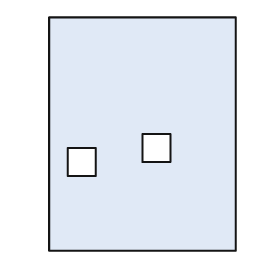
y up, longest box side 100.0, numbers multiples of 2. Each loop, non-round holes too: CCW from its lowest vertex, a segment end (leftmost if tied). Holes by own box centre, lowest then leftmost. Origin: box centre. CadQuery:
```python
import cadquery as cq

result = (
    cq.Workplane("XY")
    .moveTo(-40.0, -50.0)
    .lineTo(40.0, -50.0)
    .lineTo(40.0, 50.0)
    .lineTo(-40.0, 50.0)
    .close()
    .moveTo(-32.0, -18.0)
    .lineTo(-20.0, -18.0)
    .lineTo(-20.0, -6.0)
    .lineTo(-32.0, -6.0)
    .close()
    .moveTo(0.0, -12.0)
    .lineTo(12.0, -12.0)
    .lineTo(12.0, 0.0)
    .lineTo(0.0, 0.0)
    .close()
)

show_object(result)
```